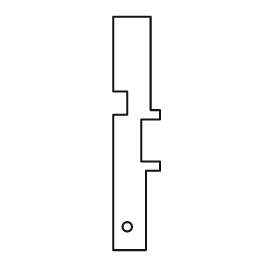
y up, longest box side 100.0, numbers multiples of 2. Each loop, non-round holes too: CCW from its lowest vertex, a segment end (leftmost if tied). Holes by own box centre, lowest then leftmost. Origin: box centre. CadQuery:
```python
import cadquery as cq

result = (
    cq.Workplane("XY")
    .moveTo(-10.0, -50.0)
    .lineTo(4.0, -50.0)
    .lineTo(4.0, -16.0)
    .lineTo(10.0, -16.0)
    .lineTo(10.0, -12.0)
    .lineTo(2.0, -12.0)
    .lineTo(2.0, 6.0)
    .lineTo(10.0, 6.0)
    .lineTo(10.0, 10.0)
    .lineTo(6.0, 10.0)
    .lineTo(6.0, 50.0)
    .lineTo(-10.0, 50.0)
    .lineTo(-10.0, 18.0)
    .lineTo(-4.0, 18.0)
    .lineTo(-4.0, 8.0)
    .lineTo(-10.0, 8.0)
    .close()
    .moveTo(-4.0, -40.0)
    .circle(2.0)
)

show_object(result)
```